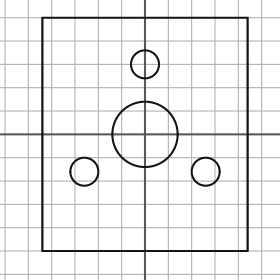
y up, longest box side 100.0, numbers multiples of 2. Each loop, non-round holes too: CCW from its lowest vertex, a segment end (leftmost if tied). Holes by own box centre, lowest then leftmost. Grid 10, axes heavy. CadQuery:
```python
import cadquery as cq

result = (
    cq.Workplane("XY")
    .moveTo(-44.0, -50.0)
    .lineTo(44.0, -50.0)
    .lineTo(44.0, 50.0)
    .lineTo(-44.0, 50.0)
    .close()
    .moveTo(-26.0, -16.0)
    .circle(6.0)
    .moveTo(26.0, -16.0)
    .circle(6.0)
    .moveTo(0.0, 0.0)
    .circle(14.0)
    .moveTo(0.0, 30.0)
    .circle(6.0)
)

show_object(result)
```